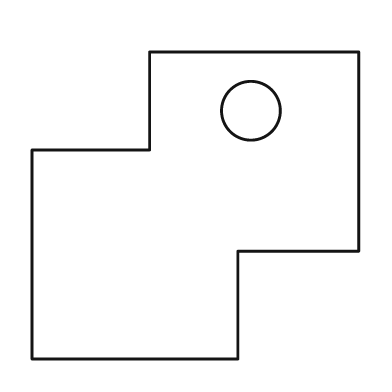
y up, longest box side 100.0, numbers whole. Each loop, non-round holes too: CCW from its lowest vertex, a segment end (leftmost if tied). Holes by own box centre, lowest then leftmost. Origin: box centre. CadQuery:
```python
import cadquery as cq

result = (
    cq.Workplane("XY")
    .moveTo(-50.0, -47.0)
    .lineTo(13.0, -47.0)
    .lineTo(13.0, -14.0)
    .lineTo(50.0, -14.0)
    .lineTo(50.0, 47.0)
    .lineTo(-14.0, 47.0)
    .lineTo(-14.0, 17.0)
    .lineTo(-50.0, 17.0)
    .close()
    .moveTo(17.0, 29.0)
    .circle(9.0)
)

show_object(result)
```